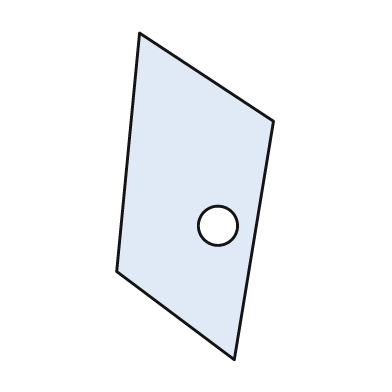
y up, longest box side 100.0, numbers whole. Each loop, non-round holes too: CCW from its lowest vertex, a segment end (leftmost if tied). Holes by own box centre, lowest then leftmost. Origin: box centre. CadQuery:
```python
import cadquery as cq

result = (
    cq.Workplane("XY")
    .moveTo(12.0, -50.0)
    .lineTo(24.0, 23.0)
    .lineTo(-17.0, 50.0)
    .lineTo(-24.0, -23.0)
    .close()
    .moveTo(7.0, -9.0)
    .circle(6.0)
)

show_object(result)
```